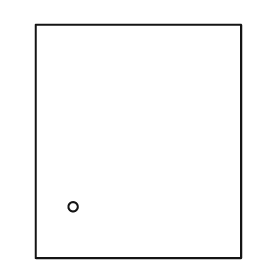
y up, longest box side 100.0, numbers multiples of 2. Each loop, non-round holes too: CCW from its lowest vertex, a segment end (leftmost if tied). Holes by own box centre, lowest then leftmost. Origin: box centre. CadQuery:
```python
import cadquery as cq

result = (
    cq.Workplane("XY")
    .moveTo(-44.0, -50.0)
    .lineTo(44.0, -50.0)
    .lineTo(44.0, 50.0)
    .lineTo(-44.0, 50.0)
    .close()
    .moveTo(-28.0, -28.0)
    .circle(2.0)
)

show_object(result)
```